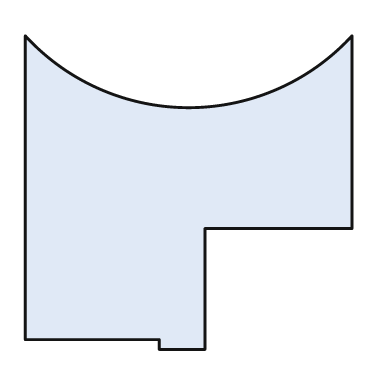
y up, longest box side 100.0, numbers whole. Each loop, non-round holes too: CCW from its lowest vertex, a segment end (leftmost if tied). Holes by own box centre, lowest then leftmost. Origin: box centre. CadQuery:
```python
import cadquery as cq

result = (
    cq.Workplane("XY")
    .moveTo(-9.0, -48.0)
    .lineTo(5.0, -48.0)
    .lineTo(5.0, -11.0)
    .lineTo(50.0, -11.0)
    .lineTo(50.0, 48.0)
    .threePointArc((0.0, 26.0), (-50.0, 48.0))
    .lineTo(-50.0, -45.0)
    .lineTo(-9.0, -45.0)
    .close()
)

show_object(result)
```